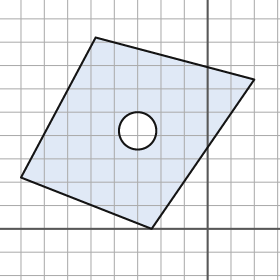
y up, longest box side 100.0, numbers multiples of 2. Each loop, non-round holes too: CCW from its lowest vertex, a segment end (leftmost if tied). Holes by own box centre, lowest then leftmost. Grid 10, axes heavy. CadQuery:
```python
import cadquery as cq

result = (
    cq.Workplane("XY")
    .moveTo(-24.0, 0.0)
    .lineTo(20.0, 64.0)
    .lineTo(-48.0, 82.0)
    .lineTo(-80.0, 22.0)
    .close()
    .moveTo(-30.0, 42.0)
    .circle(8.0)
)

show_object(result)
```